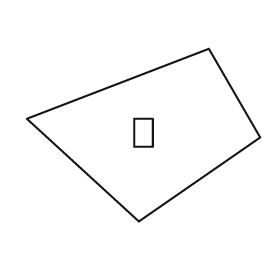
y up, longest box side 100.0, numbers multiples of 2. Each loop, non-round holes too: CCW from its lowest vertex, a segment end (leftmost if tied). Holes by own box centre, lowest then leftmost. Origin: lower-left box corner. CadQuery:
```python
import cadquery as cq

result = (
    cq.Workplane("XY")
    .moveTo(48.0, 0.0)
    .lineTo(100.0, 36.0)
    .lineTo(78.0, 74.0)
    .lineTo(0.0, 44.0)
    .close()
    .moveTo(46.0, 32.0)
    .lineTo(54.0, 32.0)
    .lineTo(54.0, 44.0)
    .lineTo(46.0, 44.0)
    .close()
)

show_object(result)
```